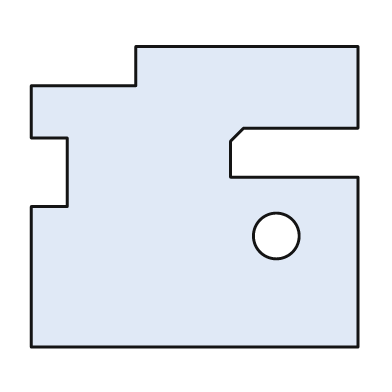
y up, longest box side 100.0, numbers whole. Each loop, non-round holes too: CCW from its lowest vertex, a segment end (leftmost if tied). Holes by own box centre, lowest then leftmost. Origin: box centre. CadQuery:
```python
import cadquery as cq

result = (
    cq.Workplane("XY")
    .moveTo(-50.0, -46.0)
    .lineTo(50.0, -46.0)
    .lineTo(50.0, 6.0)
    .lineTo(11.0, 6.0)
    .lineTo(11.0, 17.0)
    .lineTo(15.0, 21.0)
    .lineTo(50.0, 21.0)
    .lineTo(50.0, 46.0)
    .lineTo(-18.0, 46.0)
    .lineTo(-18.0, 34.0)
    .lineTo(-50.0, 34.0)
    .lineTo(-50.0, 18.0)
    .lineTo(-39.0, 18.0)
    .lineTo(-39.0, -3.0)
    .lineTo(-50.0, -3.0)
    .close()
    .moveTo(25.0, -12.0)
    .circle(7.0)
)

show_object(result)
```